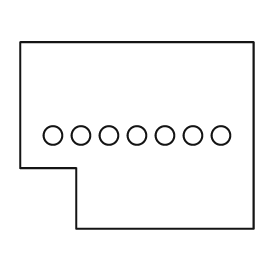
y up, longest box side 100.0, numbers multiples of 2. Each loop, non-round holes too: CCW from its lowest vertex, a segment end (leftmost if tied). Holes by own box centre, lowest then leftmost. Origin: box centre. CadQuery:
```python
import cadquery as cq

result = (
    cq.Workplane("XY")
    .moveTo(-26.0, -40.0)
    .lineTo(50.0, -40.0)
    .lineTo(50.0, 40.0)
    .lineTo(-50.0, 40.0)
    .lineTo(-50.0, -14.0)
    .lineTo(-26.0, -14.0)
    .close()
    .moveTo(-36.0, 0.0)
    .circle(4.0)
    .moveTo(-24.0, 0.0)
    .circle(4.0)
    .moveTo(-12.0, 0.0)
    .circle(4.0)
    .moveTo(0.0, 0.0)
    .circle(4.0)
    .moveTo(12.0, 0.0)
    .circle(4.0)
    .moveTo(24.0, 0.0)
    .circle(4.0)
    .moveTo(36.0, 0.0)
    .circle(4.0)
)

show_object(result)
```